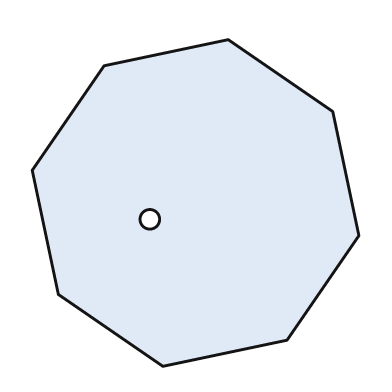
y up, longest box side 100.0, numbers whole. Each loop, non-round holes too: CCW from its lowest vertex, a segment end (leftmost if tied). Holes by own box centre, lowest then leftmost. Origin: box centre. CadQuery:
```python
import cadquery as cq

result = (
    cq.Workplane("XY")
    .moveTo(-10.0, -50.0)
    .lineTo(28.0, -42.0)
    .lineTo(50.0, -10.0)
    .lineTo(42.0, 28.0)
    .lineTo(10.0, 50.0)
    .lineTo(-28.0, 42.0)
    .lineTo(-50.0, 10.0)
    .lineTo(-42.0, -28.0)
    .close()
    .moveTo(-14.0, -5.0)
    .circle(3.0)
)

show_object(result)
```